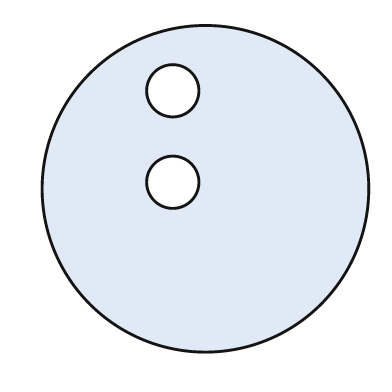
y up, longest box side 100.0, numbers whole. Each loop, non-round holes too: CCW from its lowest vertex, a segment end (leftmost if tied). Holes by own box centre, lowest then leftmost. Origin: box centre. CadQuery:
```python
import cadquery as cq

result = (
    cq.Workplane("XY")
    .moveTo(0.0, 0.0)
    .circle(50.0)
    .moveTo(-10.0, 2.0)
    .circle(8.0)
    .moveTo(-10.0, 30.0)
    .circle(8.0)
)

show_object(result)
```